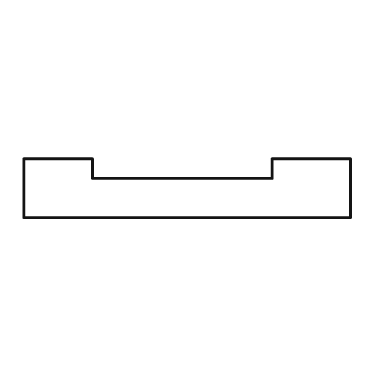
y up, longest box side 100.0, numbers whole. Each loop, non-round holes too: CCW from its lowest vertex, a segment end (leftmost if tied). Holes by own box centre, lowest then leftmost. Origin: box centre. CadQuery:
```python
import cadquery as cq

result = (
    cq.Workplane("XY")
    .moveTo(-50.0, -9.0)
    .lineTo(50.0, -9.0)
    .lineTo(50.0, 9.0)
    .lineTo(26.0, 9.0)
    .lineTo(26.0, 3.0)
    .lineTo(-29.0, 3.0)
    .lineTo(-29.0, 9.0)
    .lineTo(-50.0, 9.0)
    .close()
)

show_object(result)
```